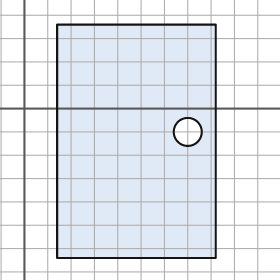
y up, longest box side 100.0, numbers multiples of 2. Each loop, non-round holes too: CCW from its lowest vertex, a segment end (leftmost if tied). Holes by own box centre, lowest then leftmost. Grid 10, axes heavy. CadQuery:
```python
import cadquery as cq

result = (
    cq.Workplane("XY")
    .moveTo(14.0, -64.0)
    .lineTo(82.0, -64.0)
    .lineTo(82.0, 36.0)
    .lineTo(14.0, 36.0)
    .close()
    .moveTo(70.0, -10.0)
    .circle(6.0)
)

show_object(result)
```